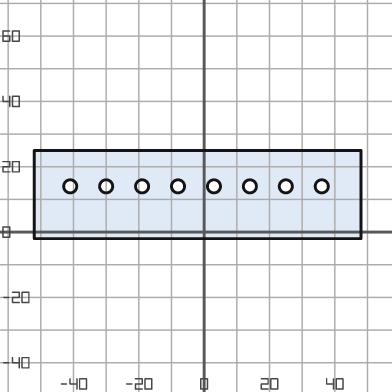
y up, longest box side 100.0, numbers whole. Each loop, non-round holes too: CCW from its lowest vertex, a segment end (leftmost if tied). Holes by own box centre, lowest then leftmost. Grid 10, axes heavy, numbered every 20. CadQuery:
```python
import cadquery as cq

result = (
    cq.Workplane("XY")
    .moveTo(-52.0, -2.0)
    .lineTo(48.0, -2.0)
    .lineTo(48.0, 25.0)
    .lineTo(-52.0, 25.0)
    .close()
    .moveTo(-41.0, 14.0)
    .circle(2.0)
    .moveTo(-30.0, 14.0)
    .circle(2.0)
    .moveTo(-19.0, 14.0)
    .circle(2.0)
    .moveTo(-8.0, 14.0)
    .circle(2.0)
    .moveTo(3.0, 14.0)
    .circle(2.0)
    .moveTo(14.0, 14.0)
    .circle(2.0)
    .moveTo(25.0, 14.0)
    .circle(2.0)
    .moveTo(36.0, 14.0)
    .circle(2.0)
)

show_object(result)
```